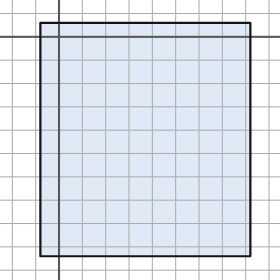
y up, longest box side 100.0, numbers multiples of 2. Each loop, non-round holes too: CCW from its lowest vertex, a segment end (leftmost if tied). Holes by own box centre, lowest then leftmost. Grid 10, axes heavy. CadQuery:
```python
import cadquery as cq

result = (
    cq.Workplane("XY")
    .moveTo(-8.0, -94.0)
    .lineTo(82.0, -94.0)
    .lineTo(82.0, 6.0)
    .lineTo(-8.0, 6.0)
    .close()
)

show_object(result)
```